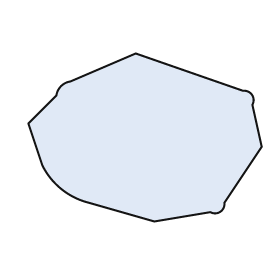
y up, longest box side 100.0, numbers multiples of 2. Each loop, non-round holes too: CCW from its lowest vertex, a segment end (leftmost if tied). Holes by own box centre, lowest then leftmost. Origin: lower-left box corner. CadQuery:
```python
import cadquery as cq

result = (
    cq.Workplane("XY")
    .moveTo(54.0, 0.0)
    .lineTo(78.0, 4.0)
    .threePointArc((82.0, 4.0), (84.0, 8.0))
    .lineTo(100.0, 32.0)
    .lineTo(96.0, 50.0)
    .threePointArc((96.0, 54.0), (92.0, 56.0))
    .lineTo(46.0, 72.0)
    .lineTo(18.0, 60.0)
    .threePointArc((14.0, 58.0), (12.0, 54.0))
    .lineTo(0.0, 42.0)
    .lineTo(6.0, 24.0)
    .threePointArc((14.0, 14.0), (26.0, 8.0))
    .close()
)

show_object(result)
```